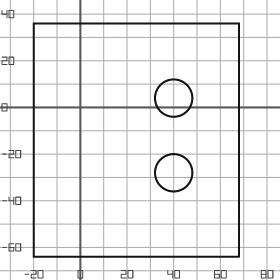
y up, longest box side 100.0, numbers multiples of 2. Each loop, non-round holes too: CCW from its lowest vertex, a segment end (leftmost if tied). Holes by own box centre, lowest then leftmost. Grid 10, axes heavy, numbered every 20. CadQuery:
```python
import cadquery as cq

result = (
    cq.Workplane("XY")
    .moveTo(-20.0, -64.0)
    .lineTo(68.0, -64.0)
    .lineTo(68.0, 36.0)
    .lineTo(-20.0, 36.0)
    .close()
    .moveTo(40.0, -28.0)
    .circle(8.0)
    .moveTo(40.0, 4.0)
    .circle(8.0)
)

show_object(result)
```